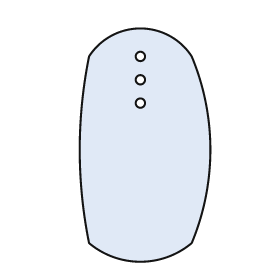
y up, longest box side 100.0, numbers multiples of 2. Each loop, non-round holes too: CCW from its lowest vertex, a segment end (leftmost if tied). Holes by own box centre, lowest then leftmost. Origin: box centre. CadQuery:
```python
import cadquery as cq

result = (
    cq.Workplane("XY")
    .moveTo(-24.0, -42.0)
    .threePointArc((-2.0, -50.0), (20.0, -42.0))
    .threePointArc((28.0, -2.0), (20.0, 38.0))
    .threePointArc((-2.0, 50.0), (-24.0, 38.0))
    .threePointArc((-28.0, -2.0), (-24.0, -42.0))
    .close()
    .moveTo(-2.0, 18.0)
    .circle(2.0)
    .moveTo(-2.0, 28.0)
    .circle(2.0)
    .moveTo(-2.0, 38.0)
    .circle(2.0)
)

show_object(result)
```